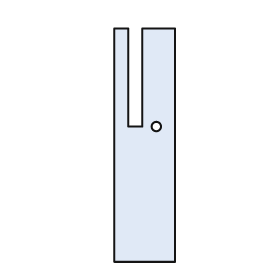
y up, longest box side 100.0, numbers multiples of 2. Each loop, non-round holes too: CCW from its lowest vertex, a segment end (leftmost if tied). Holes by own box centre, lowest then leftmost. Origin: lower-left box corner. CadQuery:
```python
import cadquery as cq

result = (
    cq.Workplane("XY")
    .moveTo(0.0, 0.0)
    .lineTo(26.0, 0.0)
    .lineTo(26.0, 100.0)
    .lineTo(12.0, 100.0)
    .lineTo(12.0, 58.0)
    .lineTo(6.0, 58.0)
    .lineTo(6.0, 100.0)
    .lineTo(0.0, 100.0)
    .close()
    .moveTo(18.0, 58.0)
    .circle(2.0)
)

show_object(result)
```